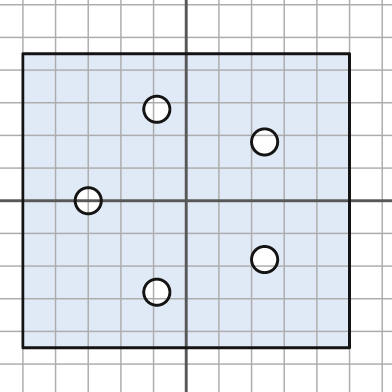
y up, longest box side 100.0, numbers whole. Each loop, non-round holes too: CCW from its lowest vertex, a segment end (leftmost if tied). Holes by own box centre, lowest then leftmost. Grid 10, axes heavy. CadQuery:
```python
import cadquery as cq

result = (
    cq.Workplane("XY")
    .moveTo(-50.0, -45.0)
    .lineTo(50.0, -45.0)
    .lineTo(50.0, 45.0)
    .lineTo(-50.0, 45.0)
    .close()
    .moveTo(-9.0, -28.0)
    .circle(4.0)
    .moveTo(24.0, -18.0)
    .circle(4.0)
    .moveTo(-30.0, 0.0)
    .circle(4.0)
    .moveTo(24.0, 18.0)
    .circle(4.0)
    .moveTo(-9.0, 28.0)
    .circle(4.0)
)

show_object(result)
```